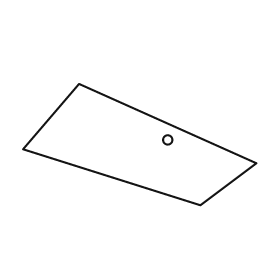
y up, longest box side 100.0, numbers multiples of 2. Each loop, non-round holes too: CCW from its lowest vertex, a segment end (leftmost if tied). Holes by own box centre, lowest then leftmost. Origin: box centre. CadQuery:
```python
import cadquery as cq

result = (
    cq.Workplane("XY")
    .moveTo(26.0, -26.0)
    .lineTo(50.0, -8.0)
    .lineTo(-26.0, 26.0)
    .lineTo(-50.0, -2.0)
    .close()
    .moveTo(12.0, 2.0)
    .circle(2.0)
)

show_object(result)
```